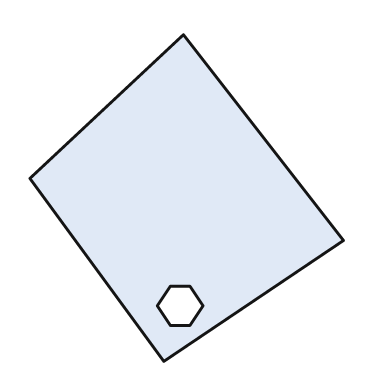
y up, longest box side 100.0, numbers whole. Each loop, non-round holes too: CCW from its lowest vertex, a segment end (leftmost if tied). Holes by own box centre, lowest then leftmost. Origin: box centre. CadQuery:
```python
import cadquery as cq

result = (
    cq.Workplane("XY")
    .moveTo(-7.0, -50.0)
    .lineTo(48.0, -13.0)
    .lineTo(-1.0, 50.0)
    .lineTo(-48.0, 6.0)
    .close()
    .moveTo(-5.0, -39.0)
    .lineTo(1.0, -39.0)
    .lineTo(5.0, -33.0)
    .lineTo(1.0, -27.0)
    .lineTo(-5.0, -27.0)
    .lineTo(-9.0, -33.0)
    .close()
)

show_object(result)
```